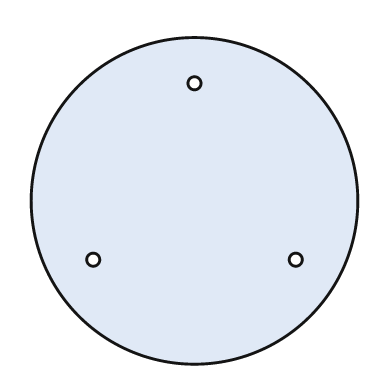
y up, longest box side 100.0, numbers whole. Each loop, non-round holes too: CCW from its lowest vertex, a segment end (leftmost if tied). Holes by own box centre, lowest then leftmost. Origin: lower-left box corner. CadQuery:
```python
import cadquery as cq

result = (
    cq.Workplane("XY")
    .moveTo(50.0, 50.0)
    .circle(50.0)
    .moveTo(19.0, 32.0)
    .circle(2.0)
    .moveTo(81.0, 32.0)
    .circle(2.0)
    .moveTo(50.0, 86.0)
    .circle(2.0)
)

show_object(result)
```